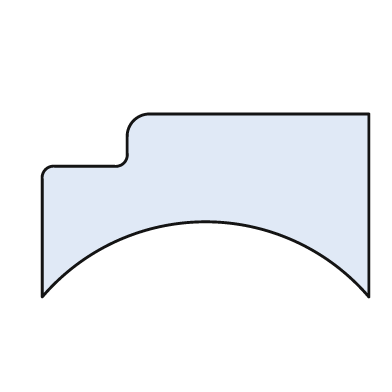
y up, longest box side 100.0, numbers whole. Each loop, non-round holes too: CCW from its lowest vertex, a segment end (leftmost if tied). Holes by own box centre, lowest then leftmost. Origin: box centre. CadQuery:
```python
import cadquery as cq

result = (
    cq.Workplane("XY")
    .moveTo(-50.0, -28.0)
    .threePointArc((0.0, -5.0), (50.0, -28.0))
    .lineTo(50.0, 28.0)
    .lineTo(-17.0, 28.0)
    .threePointArc((-22.0, 26.0), (-24.0, 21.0))
    .lineTo(-24.0, 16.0)
    .threePointArc((-25.0, 13.0), (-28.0, 12.0))
    .lineTo(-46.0, 12.0)
    .threePointArc((-49.0, 11.0), (-50.0, 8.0))
    .close()
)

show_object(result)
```